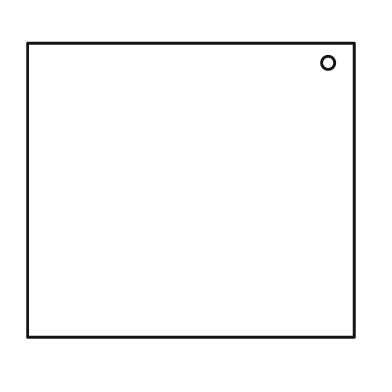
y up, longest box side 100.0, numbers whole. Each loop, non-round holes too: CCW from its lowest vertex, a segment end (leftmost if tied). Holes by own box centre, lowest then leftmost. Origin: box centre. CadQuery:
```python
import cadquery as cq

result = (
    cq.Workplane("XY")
    .moveTo(-50.0, -45.0)
    .lineTo(50.0, -45.0)
    .lineTo(50.0, 45.0)
    .lineTo(-50.0, 45.0)
    .close()
    .moveTo(42.0, 39.0)
    .circle(2.0)
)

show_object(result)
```